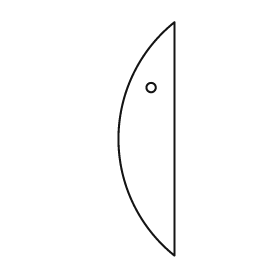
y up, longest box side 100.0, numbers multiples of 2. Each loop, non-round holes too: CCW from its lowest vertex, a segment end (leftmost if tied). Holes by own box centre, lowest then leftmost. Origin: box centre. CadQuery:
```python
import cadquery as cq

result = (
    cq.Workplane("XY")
    .moveTo(12.0, -50.0)
    .lineTo(12.0, 50.0)
    .threePointArc((-12.0, 0.0), (12.0, -50.0))
    .close()
    .moveTo(2.0, 22.0)
    .circle(2.0)
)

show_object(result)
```